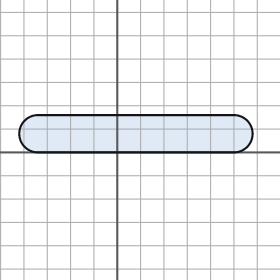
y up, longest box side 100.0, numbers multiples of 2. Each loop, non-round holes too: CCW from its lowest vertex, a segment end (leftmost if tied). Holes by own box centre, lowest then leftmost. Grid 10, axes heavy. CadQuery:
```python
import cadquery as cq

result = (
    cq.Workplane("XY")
    .moveTo(-34.0, 0.0)
    .lineTo(50.0, 0.0)
    .threePointArc((58.0, 8.0), (50.0, 16.0))
    .lineTo(-34.0, 16.0)
    .threePointArc((-42.0, 8.0), (-34.0, 0.0))
    .close()
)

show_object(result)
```